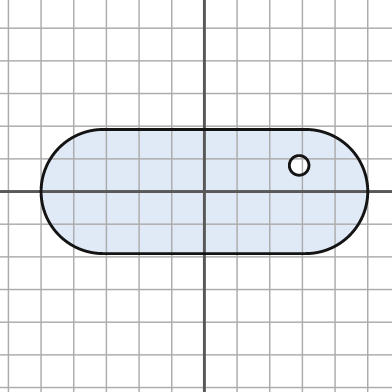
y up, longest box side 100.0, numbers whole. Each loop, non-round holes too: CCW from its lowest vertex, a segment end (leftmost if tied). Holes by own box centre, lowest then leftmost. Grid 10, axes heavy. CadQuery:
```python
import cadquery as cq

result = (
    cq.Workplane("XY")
    .moveTo(-31.0, -19.0)
    .lineTo(31.0, -19.0)
    .threePointArc((50.0, 0.0), (31.0, 19.0))
    .lineTo(-31.0, 19.0)
    .threePointArc((-50.0, 0.0), (-31.0, -19.0))
    .close()
    .moveTo(29.0, 8.0)
    .circle(3.0)
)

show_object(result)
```